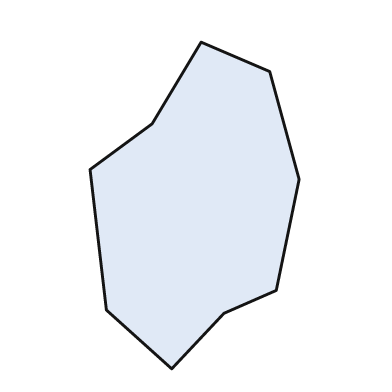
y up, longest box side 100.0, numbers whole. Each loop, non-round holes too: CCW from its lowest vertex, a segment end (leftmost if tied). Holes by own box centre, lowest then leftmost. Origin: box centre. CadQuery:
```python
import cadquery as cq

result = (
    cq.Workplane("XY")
    .moveTo(-7.0, -50.0)
    .lineTo(9.0, -33.0)
    .lineTo(25.0, -26.0)
    .lineTo(32.0, 8.0)
    .lineTo(23.0, 41.0)
    .lineTo(2.0, 50.0)
    .lineTo(-13.0, 25.0)
    .lineTo(-32.0, 11.0)
    .lineTo(-27.0, -32.0)
    .close()
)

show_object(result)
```